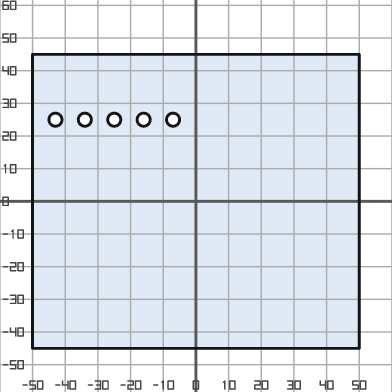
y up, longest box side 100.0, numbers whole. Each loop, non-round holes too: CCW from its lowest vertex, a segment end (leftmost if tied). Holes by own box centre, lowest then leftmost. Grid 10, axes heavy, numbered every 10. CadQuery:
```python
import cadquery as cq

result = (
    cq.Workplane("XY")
    .moveTo(-50.0, -45.0)
    .lineTo(50.0, -45.0)
    .lineTo(50.0, 45.0)
    .lineTo(-50.0, 45.0)
    .close()
    .moveTo(-43.0, 25.0)
    .circle(2.0)
    .moveTo(-34.0, 25.0)
    .circle(2.0)
    .moveTo(-25.0, 25.0)
    .circle(2.0)
    .moveTo(-16.0, 25.0)
    .circle(2.0)
    .moveTo(-7.0, 25.0)
    .circle(2.0)
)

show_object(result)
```